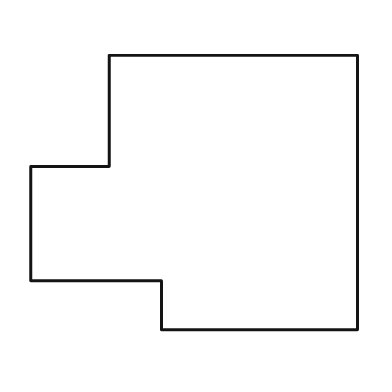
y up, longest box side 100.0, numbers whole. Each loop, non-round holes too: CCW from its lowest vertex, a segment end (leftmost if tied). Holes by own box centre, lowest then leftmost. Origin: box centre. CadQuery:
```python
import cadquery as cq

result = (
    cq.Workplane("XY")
    .moveTo(-10.0, -42.0)
    .lineTo(50.0, -42.0)
    .lineTo(50.0, 42.0)
    .lineTo(-26.0, 42.0)
    .lineTo(-26.0, 8.0)
    .lineTo(-50.0, 8.0)
    .lineTo(-50.0, -27.0)
    .lineTo(-10.0, -27.0)
    .close()
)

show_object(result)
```